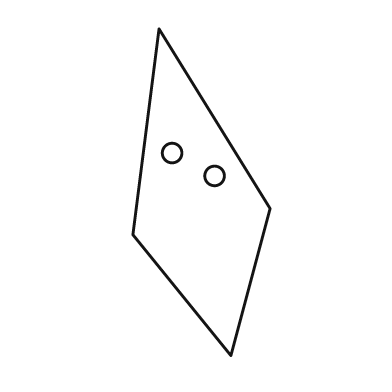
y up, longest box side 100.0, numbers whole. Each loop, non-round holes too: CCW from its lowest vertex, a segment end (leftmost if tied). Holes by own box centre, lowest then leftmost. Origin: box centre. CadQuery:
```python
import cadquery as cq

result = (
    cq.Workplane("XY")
    .moveTo(9.0, -50.0)
    .lineTo(21.0, -5.0)
    .lineTo(-13.0, 50.0)
    .lineTo(-21.0, -13.0)
    .close()
    .moveTo(4.0, 5.0)
    .circle(3.0)
    .moveTo(-9.0, 12.0)
    .circle(3.0)
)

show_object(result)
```